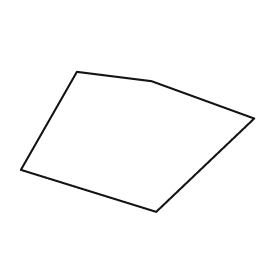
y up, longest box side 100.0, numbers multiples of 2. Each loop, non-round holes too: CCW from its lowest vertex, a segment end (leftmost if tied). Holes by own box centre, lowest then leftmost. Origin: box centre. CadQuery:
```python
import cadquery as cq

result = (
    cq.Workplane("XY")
    .moveTo(8.0, -30.0)
    .lineTo(50.0, 10.0)
    .lineTo(6.0, 26.0)
    .lineTo(-26.0, 30.0)
    .lineTo(-50.0, -12.0)
    .close()
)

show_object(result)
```